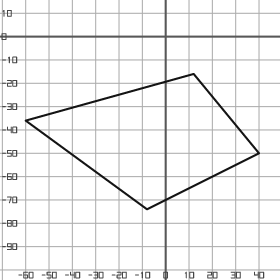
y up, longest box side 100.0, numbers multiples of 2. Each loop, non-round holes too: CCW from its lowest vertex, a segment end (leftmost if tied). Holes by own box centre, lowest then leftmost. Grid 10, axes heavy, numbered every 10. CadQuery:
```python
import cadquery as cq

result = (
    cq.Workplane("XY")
    .moveTo(-8.0, -74.0)
    .lineTo(40.0, -50.0)
    .lineTo(12.0, -16.0)
    .lineTo(-60.0, -36.0)
    .close()
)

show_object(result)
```